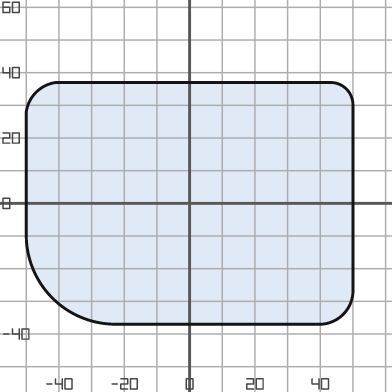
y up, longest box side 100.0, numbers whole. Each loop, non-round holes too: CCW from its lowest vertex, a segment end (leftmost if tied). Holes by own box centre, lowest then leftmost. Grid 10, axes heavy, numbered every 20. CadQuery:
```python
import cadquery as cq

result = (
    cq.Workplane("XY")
    .moveTo(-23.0, -37.0)
    .lineTo(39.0, -37.0)
    .threePointArc((47.0, -34.0), (50.0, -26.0))
    .lineTo(50.0, 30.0)
    .threePointArc((48.0, 35.0), (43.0, 37.0))
    .lineTo(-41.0, 37.0)
    .threePointArc((-47.0, 34.0), (-50.0, 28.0))
    .lineTo(-50.0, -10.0)
    .threePointArc((-42.0, -29.0), (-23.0, -37.0))
    .close()
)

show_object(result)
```